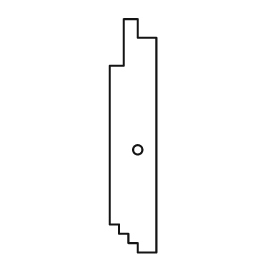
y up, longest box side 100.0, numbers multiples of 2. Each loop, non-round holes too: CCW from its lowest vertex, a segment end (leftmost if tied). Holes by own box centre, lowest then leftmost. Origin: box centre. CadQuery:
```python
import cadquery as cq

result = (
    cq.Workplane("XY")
    .moveTo(2.0, -50.0)
    .lineTo(10.0, -50.0)
    .lineTo(10.0, 42.0)
    .lineTo(2.0, 42.0)
    .lineTo(2.0, 50.0)
    .lineTo(-4.0, 50.0)
    .lineTo(-4.0, 30.0)
    .lineTo(-10.0, 30.0)
    .lineTo(-10.0, -38.0)
    .lineTo(-6.0, -38.0)
    .lineTo(-6.0, -42.0)
    .lineTo(-2.0, -42.0)
    .lineTo(-2.0, -46.0)
    .lineTo(2.0, -46.0)
    .close()
    .moveTo(2.0, -6.0)
    .circle(2.0)
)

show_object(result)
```